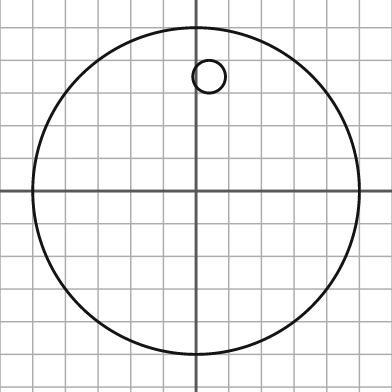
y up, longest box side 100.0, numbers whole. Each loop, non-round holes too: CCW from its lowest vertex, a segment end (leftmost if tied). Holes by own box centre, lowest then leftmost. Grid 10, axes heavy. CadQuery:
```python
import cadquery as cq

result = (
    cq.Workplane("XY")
    .moveTo(0.0, 0.0)
    .circle(50.0)
    .moveTo(4.0, 35.0)
    .circle(5.0)
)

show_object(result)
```